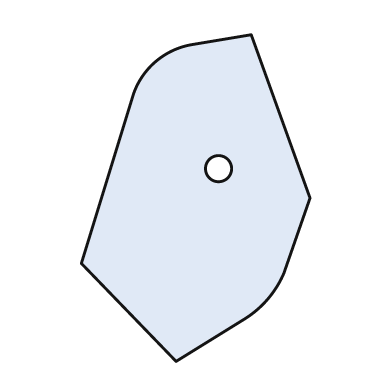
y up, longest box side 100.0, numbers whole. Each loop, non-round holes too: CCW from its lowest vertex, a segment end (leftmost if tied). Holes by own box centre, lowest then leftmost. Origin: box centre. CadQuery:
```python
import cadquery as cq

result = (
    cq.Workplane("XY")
    .moveTo(-6.0, -50.0)
    .lineTo(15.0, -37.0)
    .threePointArc((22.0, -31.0), (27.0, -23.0))
    .lineTo(35.0, 0.0)
    .lineTo(17.0, 50.0)
    .lineTo(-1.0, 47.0)
    .threePointArc((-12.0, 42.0), (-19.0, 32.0))
    .lineTo(-35.0, -20.0)
    .close()
    .moveTo(7.0, 9.0)
    .circle(4.0)
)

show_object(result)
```